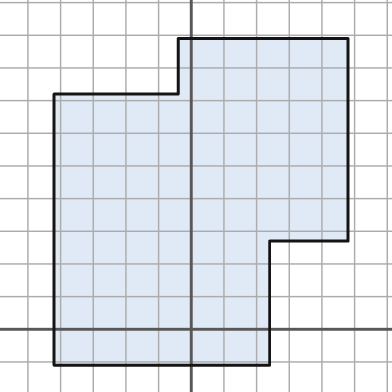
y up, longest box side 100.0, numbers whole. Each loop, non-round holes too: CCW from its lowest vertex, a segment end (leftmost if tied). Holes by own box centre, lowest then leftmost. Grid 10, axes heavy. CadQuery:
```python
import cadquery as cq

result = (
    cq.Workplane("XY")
    .moveTo(-42.0, -11.0)
    .lineTo(24.0, -11.0)
    .lineTo(24.0, 27.0)
    .lineTo(48.0, 27.0)
    .lineTo(48.0, 89.0)
    .lineTo(-4.0, 89.0)
    .lineTo(-4.0, 72.0)
    .lineTo(-42.0, 72.0)
    .close()
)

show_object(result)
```